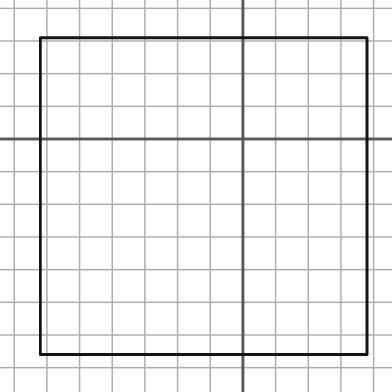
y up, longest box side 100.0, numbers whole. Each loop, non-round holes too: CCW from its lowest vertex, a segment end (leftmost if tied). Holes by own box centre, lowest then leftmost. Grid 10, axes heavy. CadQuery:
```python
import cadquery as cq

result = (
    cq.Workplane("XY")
    .moveTo(-62.0, -66.0)
    .lineTo(38.0, -66.0)
    .lineTo(38.0, 31.0)
    .lineTo(-62.0, 31.0)
    .close()
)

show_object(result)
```